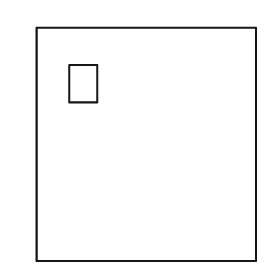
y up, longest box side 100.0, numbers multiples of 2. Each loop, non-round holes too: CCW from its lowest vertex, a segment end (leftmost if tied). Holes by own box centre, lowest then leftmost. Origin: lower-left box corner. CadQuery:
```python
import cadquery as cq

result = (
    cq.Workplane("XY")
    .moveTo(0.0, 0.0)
    .lineTo(94.0, 0.0)
    .lineTo(94.0, 100.0)
    .lineTo(0.0, 100.0)
    .close()
    .moveTo(14.0, 68.0)
    .lineTo(26.0, 68.0)
    .lineTo(26.0, 84.0)
    .lineTo(14.0, 84.0)
    .close()
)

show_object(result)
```